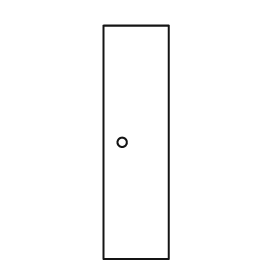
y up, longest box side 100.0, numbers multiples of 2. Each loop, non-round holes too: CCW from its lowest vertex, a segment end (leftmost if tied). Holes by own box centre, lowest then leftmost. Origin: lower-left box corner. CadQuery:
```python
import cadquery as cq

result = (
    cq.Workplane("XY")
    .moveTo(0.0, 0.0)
    .lineTo(28.0, 0.0)
    .lineTo(28.0, 100.0)
    .lineTo(0.0, 100.0)
    .close()
    .moveTo(8.0, 50.0)
    .circle(2.0)
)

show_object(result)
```